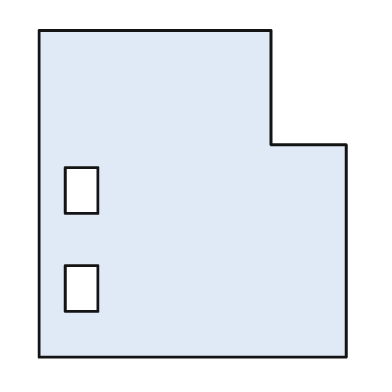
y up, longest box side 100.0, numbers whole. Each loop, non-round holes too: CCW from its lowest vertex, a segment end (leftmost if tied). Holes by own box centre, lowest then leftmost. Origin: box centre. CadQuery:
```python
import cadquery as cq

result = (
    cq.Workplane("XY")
    .moveTo(-47.0, -50.0)
    .lineTo(47.0, -50.0)
    .lineTo(47.0, 15.0)
    .lineTo(24.0, 15.0)
    .lineTo(24.0, 50.0)
    .lineTo(-47.0, 50.0)
    .close()
    .moveTo(-39.0, -36.0)
    .lineTo(-29.0, -36.0)
    .lineTo(-29.0, -22.0)
    .lineTo(-39.0, -22.0)
    .close()
    .moveTo(-39.0, -6.0)
    .lineTo(-29.0, -6.0)
    .lineTo(-29.0, 8.0)
    .lineTo(-39.0, 8.0)
    .close()
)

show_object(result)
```